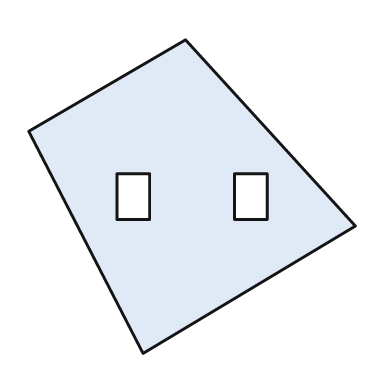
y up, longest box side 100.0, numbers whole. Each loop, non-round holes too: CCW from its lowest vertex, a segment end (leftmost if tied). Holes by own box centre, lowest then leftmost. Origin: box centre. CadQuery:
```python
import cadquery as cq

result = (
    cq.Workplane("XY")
    .moveTo(-15.0, -48.0)
    .lineTo(50.0, -9.0)
    .lineTo(-2.0, 48.0)
    .lineTo(-50.0, 20.0)
    .close()
    .moveTo(-23.0, -7.0)
    .lineTo(-13.0, -7.0)
    .lineTo(-13.0, 7.0)
    .lineTo(-23.0, 7.0)
    .close()
    .moveTo(13.0, -7.0)
    .lineTo(23.0, -7.0)
    .lineTo(23.0, 7.0)
    .lineTo(13.0, 7.0)
    .close()
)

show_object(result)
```